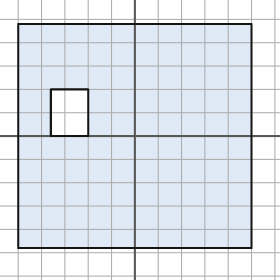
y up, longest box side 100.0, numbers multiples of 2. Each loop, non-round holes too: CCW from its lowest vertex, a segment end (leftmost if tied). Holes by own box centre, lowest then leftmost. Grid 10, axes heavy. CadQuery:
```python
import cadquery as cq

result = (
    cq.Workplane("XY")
    .moveTo(-50.0, -48.0)
    .lineTo(50.0, -48.0)
    .lineTo(50.0, 48.0)
    .lineTo(-50.0, 48.0)
    .close()
    .moveTo(-36.0, 0.0)
    .lineTo(-20.0, 0.0)
    .lineTo(-20.0, 20.0)
    .lineTo(-36.0, 20.0)
    .close()
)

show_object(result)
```